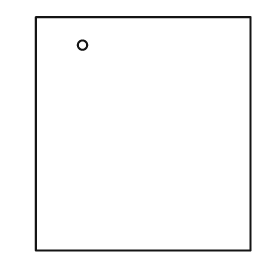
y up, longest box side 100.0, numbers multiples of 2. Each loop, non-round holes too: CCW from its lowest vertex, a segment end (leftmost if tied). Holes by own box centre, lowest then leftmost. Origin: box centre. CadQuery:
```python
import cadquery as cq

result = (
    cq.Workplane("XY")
    .moveTo(-46.0, -50.0)
    .lineTo(46.0, -50.0)
    .lineTo(46.0, 50.0)
    .lineTo(-46.0, 50.0)
    .close()
    .moveTo(-26.0, 38.0)
    .circle(2.0)
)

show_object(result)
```